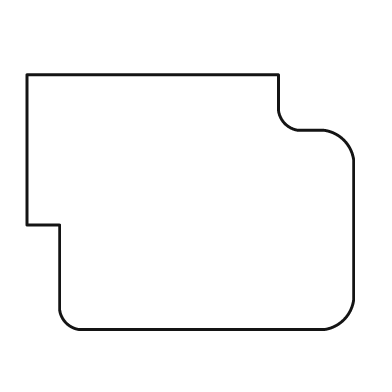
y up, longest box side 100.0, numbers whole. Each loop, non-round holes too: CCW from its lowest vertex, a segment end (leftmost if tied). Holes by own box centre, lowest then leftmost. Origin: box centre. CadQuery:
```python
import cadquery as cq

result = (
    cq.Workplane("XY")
    .moveTo(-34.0, -39.0)
    .lineTo(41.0, -39.0)
    .threePointArc((47.0, -36.0), (50.0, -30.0))
    .lineTo(50.0, 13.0)
    .threePointArc((47.0, 19.0), (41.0, 22.0))
    .lineTo(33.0, 22.0)
    .threePointArc((29.0, 24.0), (27.0, 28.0))
    .lineTo(27.0, 39.0)
    .lineTo(-50.0, 39.0)
    .lineTo(-50.0, -7.0)
    .lineTo(-40.0, -7.0)
    .lineTo(-40.0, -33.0)
    .threePointArc((-38.0, -37.0), (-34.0, -39.0))
    .close()
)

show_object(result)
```